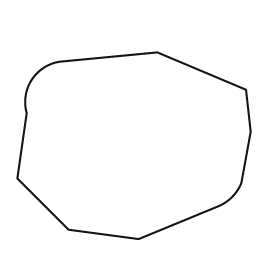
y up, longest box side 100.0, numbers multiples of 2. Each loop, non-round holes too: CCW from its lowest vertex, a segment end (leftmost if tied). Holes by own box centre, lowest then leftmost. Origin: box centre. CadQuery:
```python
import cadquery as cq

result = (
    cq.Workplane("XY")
    .moveTo(2.0, -40.0)
    .lineTo(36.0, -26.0)
    .threePointArc((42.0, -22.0), (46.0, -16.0))
    .lineTo(50.0, 6.0)
    .lineTo(48.0, 24.0)
    .lineTo(10.0, 40.0)
    .lineTo(-32.0, 36.0)
    .threePointArc((-44.0, 28.0), (-46.0, 14.0))
    .lineTo(-50.0, -14.0)
    .lineTo(-28.0, -36.0)
    .close()
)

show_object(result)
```